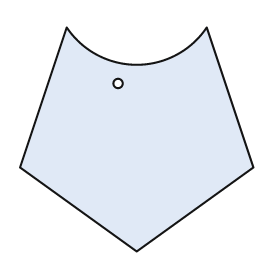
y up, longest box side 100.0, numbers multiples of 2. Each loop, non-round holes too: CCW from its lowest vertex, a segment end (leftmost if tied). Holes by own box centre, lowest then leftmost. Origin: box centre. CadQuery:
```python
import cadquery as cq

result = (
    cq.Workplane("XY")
    .moveTo(0.0, -48.0)
    .lineTo(50.0, -12.0)
    .lineTo(30.0, 48.0)
    .threePointArc((0.0, 32.0), (-30.0, 48.0))
    .lineTo(-50.0, -12.0)
    .close()
    .moveTo(-8.0, 24.0)
    .circle(2.0)
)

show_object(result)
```